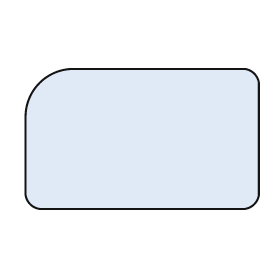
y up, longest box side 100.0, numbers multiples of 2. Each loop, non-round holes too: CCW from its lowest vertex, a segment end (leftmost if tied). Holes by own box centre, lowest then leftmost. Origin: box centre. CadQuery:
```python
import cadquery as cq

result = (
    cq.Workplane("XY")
    .moveTo(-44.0, -30.0)
    .lineTo(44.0, -30.0)
    .threePointArc((48.0, -28.0), (50.0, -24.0))
    .lineTo(50.0, 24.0)
    .threePointArc((48.0, 28.0), (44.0, 30.0))
    .lineTo(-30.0, 30.0)
    .threePointArc((-44.0, 24.0), (-50.0, 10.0))
    .lineTo(-50.0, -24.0)
    .threePointArc((-48.0, -28.0), (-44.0, -30.0))
    .close()
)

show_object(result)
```